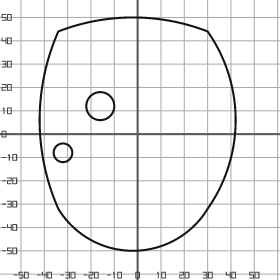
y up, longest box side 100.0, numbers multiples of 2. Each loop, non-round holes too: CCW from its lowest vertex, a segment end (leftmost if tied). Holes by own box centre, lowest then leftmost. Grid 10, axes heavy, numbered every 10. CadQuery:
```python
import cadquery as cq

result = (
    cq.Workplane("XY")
    .moveTo(-34.0, -32.0)
    .threePointArc((-2.0, -50.0), (30.0, -32.0))
    .threePointArc((42.0, 6.0), (30.0, 44.0))
    .threePointArc((-2.0, 50.0), (-34.0, 44.0))
    .threePointArc((-42.0, 6.0), (-34.0, -32.0))
    .close()
    .moveTo(-32.0, -8.0)
    .circle(4.0)
    .moveTo(-16.0, 12.0)
    .circle(6.0)
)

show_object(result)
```